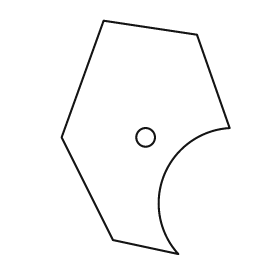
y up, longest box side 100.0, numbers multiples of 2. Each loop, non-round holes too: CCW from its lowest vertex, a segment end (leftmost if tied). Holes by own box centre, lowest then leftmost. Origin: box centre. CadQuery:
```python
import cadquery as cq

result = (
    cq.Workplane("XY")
    .moveTo(14.0, -50.0)
    .threePointArc((8.0, -16.0), (36.0, 4.0))
    .lineTo(22.0, 44.0)
    .lineTo(-18.0, 50.0)
    .lineTo(-36.0, 0.0)
    .lineTo(-14.0, -44.0)
    .close()
    .moveTo(0.0, 0.0)
    .circle(4.0)
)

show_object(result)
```